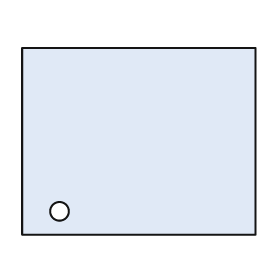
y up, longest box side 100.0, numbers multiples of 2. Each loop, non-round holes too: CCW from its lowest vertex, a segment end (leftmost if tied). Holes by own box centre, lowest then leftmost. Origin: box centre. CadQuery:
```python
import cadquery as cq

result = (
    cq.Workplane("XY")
    .moveTo(-50.0, -40.0)
    .lineTo(50.0, -40.0)
    .lineTo(50.0, 40.0)
    .lineTo(-50.0, 40.0)
    .close()
    .moveTo(-34.0, -30.0)
    .circle(4.0)
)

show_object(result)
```